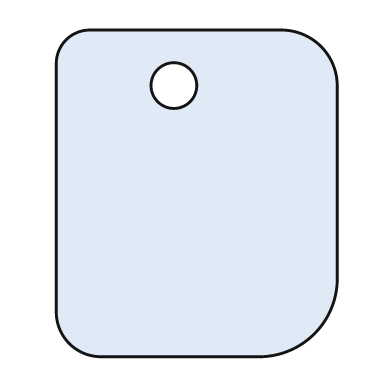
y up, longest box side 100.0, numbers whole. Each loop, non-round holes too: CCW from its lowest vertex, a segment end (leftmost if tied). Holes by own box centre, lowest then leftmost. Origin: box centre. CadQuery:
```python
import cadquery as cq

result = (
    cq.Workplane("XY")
    .moveTo(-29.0, -50.0)
    .lineTo(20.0, -50.0)
    .threePointArc((36.0, -43.0), (43.0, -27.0))
    .lineTo(43.0, 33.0)
    .threePointArc((38.0, 45.0), (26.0, 50.0))
    .lineTo(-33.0, 50.0)
    .threePointArc((-40.0, 47.0), (-43.0, 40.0))
    .lineTo(-43.0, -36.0)
    .threePointArc((-39.0, -46.0), (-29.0, -50.0))
    .close()
    .moveTo(-7.0, 33.0)
    .circle(7.0)
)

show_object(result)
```